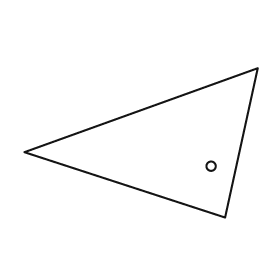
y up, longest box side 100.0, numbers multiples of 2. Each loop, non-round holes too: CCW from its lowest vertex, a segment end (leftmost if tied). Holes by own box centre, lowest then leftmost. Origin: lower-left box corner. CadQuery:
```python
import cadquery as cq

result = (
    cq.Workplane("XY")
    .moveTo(86.0, 0.0)
    .lineTo(100.0, 64.0)
    .lineTo(0.0, 28.0)
    .close()
    .moveTo(80.0, 22.0)
    .circle(2.0)
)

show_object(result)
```